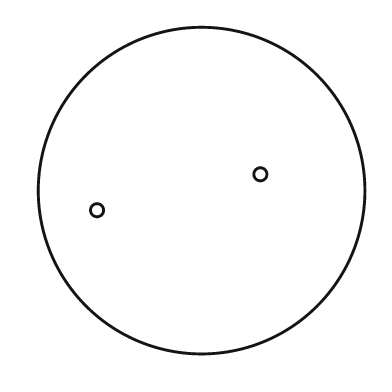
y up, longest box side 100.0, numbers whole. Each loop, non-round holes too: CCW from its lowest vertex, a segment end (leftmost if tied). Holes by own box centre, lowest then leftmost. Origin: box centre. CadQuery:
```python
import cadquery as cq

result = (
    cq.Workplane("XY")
    .moveTo(0.0, 0.0)
    .circle(50.0)
    .moveTo(-32.0, -6.0)
    .circle(2.0)
    .moveTo(18.0, 5.0)
    .circle(2.0)
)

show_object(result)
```